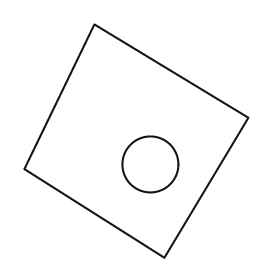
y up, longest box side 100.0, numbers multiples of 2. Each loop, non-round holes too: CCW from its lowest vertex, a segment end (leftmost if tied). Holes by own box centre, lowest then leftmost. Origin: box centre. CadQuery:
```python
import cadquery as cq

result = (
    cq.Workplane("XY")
    .moveTo(12.0, -50.0)
    .lineTo(48.0, 10.0)
    .lineTo(-18.0, 50.0)
    .lineTo(-48.0, -12.0)
    .close()
    .moveTo(6.0, -10.0)
    .circle(12.0)
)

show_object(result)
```